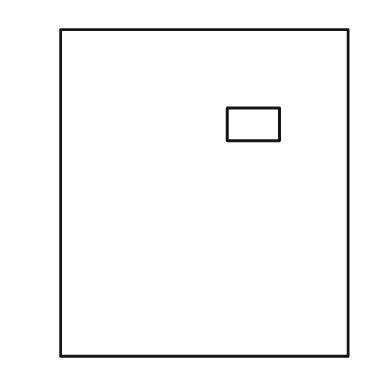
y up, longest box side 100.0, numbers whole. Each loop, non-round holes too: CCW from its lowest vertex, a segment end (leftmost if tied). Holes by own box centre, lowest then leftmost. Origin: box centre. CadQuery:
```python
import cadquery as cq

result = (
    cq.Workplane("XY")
    .moveTo(-44.0, -50.0)
    .lineTo(44.0, -50.0)
    .lineTo(44.0, 50.0)
    .lineTo(-44.0, 50.0)
    .close()
    .moveTo(7.0, 16.0)
    .lineTo(23.0, 16.0)
    .lineTo(23.0, 26.0)
    .lineTo(7.0, 26.0)
    .close()
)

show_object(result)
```